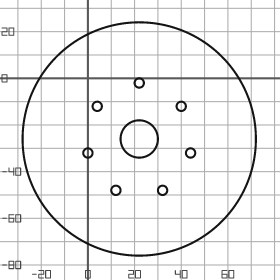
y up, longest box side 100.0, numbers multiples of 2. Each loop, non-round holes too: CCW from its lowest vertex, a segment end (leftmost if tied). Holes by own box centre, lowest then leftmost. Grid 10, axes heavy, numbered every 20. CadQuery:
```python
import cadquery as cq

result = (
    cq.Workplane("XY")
    .moveTo(22.0, -26.0)
    .circle(50.0)
    .moveTo(12.0, -48.0)
    .circle(2.0)
    .moveTo(32.0, -48.0)
    .circle(2.0)
    .moveTo(0.0, -32.0)
    .circle(2.0)
    .moveTo(44.0, -32.0)
    .circle(2.0)
    .moveTo(22.0, -26.0)
    .circle(8.0)
    .moveTo(4.0, -12.0)
    .circle(2.0)
    .moveTo(40.0, -12.0)
    .circle(2.0)
    .moveTo(22.0, -2.0)
    .circle(2.0)
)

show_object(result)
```